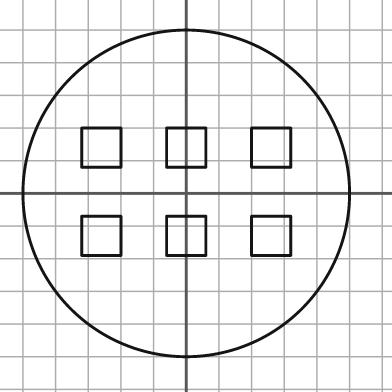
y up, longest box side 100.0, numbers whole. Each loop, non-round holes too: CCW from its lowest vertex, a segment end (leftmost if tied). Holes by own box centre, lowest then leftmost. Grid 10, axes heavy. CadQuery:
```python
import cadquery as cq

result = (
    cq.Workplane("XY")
    .moveTo(0.0, 0.0)
    .circle(50.0)
    .moveTo(-32.0, -19.0)
    .lineTo(-20.0, -19.0)
    .lineTo(-20.0, -7.0)
    .lineTo(-32.0, -7.0)
    .close()
    .moveTo(-6.0, -19.0)
    .lineTo(6.0, -19.0)
    .lineTo(6.0, -7.0)
    .lineTo(-6.0, -7.0)
    .close()
    .moveTo(20.0, -19.0)
    .lineTo(32.0, -19.0)
    .lineTo(32.0, -7.0)
    .lineTo(20.0, -7.0)
    .close()
    .moveTo(-32.0, 8.0)
    .lineTo(-20.0, 8.0)
    .lineTo(-20.0, 20.0)
    .lineTo(-32.0, 20.0)
    .close()
    .moveTo(-6.0, 8.0)
    .lineTo(6.0, 8.0)
    .lineTo(6.0, 20.0)
    .lineTo(-6.0, 20.0)
    .close()
    .moveTo(20.0, 8.0)
    .lineTo(32.0, 8.0)
    .lineTo(32.0, 20.0)
    .lineTo(20.0, 20.0)
    .close()
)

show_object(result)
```